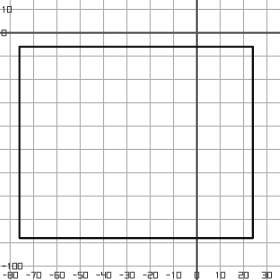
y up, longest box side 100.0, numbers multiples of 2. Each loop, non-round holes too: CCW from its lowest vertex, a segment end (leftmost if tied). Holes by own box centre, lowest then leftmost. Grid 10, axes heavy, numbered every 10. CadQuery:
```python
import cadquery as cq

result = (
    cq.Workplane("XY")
    .moveTo(-76.0, -88.0)
    .lineTo(24.0, -88.0)
    .lineTo(24.0, -6.0)
    .lineTo(-76.0, -6.0)
    .close()
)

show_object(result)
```